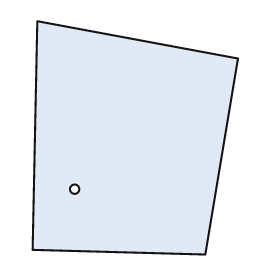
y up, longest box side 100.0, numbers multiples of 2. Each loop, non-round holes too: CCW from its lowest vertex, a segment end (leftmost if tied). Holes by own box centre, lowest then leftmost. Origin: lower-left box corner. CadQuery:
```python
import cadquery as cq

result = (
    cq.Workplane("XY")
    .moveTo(74.0, 0.0)
    .lineTo(88.0, 84.0)
    .lineTo(2.0, 100.0)
    .lineTo(0.0, 2.0)
    .close()
    .moveTo(18.0, 28.0)
    .circle(2.0)
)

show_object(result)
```